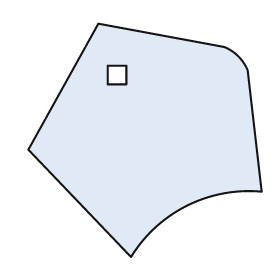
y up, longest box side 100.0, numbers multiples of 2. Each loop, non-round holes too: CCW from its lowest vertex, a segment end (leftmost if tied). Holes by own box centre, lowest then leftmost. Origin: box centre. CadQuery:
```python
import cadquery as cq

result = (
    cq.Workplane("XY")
    .moveTo(-6.0, -50.0)
    .threePointArc((18.0, -28.0), (50.0, -22.0))
    .lineTo(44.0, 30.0)
    .threePointArc((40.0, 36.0), (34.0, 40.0))
    .lineTo(-20.0, 50.0)
    .lineTo(-50.0, -4.0)
    .close()
    .moveTo(-16.0, 24.0)
    .lineTo(-8.0, 24.0)
    .lineTo(-8.0, 32.0)
    .lineTo(-16.0, 32.0)
    .close()
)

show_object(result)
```